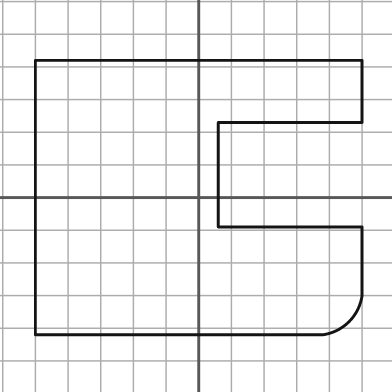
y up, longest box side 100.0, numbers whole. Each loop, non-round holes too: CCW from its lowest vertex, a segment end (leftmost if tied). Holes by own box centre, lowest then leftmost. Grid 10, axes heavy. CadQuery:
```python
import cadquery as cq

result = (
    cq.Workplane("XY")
    .moveTo(-50.0, -42.0)
    .lineTo(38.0, -42.0)
    .threePointArc((46.0, -38.0), (50.0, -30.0))
    .lineTo(50.0, -9.0)
    .lineTo(6.0, -9.0)
    .lineTo(6.0, 23.0)
    .lineTo(50.0, 23.0)
    .lineTo(50.0, 42.0)
    .lineTo(-50.0, 42.0)
    .close()
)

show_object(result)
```